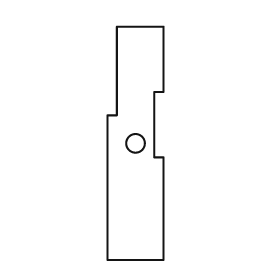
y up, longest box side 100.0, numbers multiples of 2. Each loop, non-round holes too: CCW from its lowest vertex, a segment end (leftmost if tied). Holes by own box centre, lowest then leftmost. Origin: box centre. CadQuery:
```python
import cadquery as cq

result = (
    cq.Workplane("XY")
    .moveTo(-12.0, -50.0)
    .lineTo(12.0, -50.0)
    .lineTo(12.0, -6.0)
    .lineTo(8.0, -6.0)
    .lineTo(8.0, 22.0)
    .lineTo(12.0, 22.0)
    .lineTo(12.0, 50.0)
    .lineTo(-8.0, 50.0)
    .lineTo(-8.0, 12.0)
    .lineTo(-12.0, 12.0)
    .close()
    .moveTo(0.0, 0.0)
    .circle(4.0)
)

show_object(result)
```